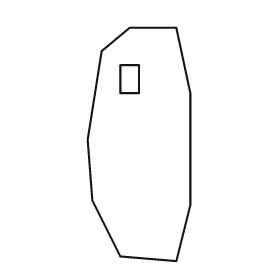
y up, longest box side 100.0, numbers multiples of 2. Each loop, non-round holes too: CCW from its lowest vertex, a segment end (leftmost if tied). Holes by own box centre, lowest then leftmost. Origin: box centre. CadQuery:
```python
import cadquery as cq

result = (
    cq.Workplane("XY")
    .moveTo(16.0, -50.0)
    .lineTo(22.0, -26.0)
    .lineTo(22.0, 22.0)
    .lineTo(16.0, 50.0)
    .lineTo(-4.0, 50.0)
    .lineTo(-16.0, 40.0)
    .lineTo(-22.0, 2.0)
    .lineTo(-20.0, -24.0)
    .lineTo(-8.0, -48.0)
    .close()
    .moveTo(-8.0, 22.0)
    .lineTo(0.0, 22.0)
    .lineTo(0.0, 34.0)
    .lineTo(-8.0, 34.0)
    .close()
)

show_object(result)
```